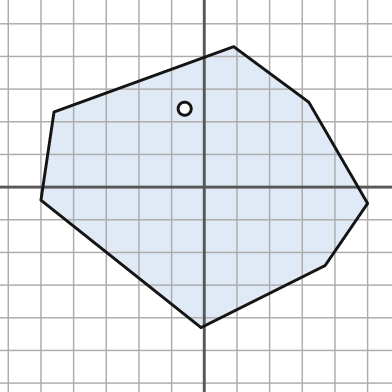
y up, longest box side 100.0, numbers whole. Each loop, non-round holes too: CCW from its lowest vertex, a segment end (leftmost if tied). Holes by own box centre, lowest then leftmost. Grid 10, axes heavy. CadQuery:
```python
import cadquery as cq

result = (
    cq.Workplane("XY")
    .moveTo(-1.0, -43.0)
    .lineTo(37.0, -24.0)
    .lineTo(50.0, -5.0)
    .lineTo(32.0, 26.0)
    .lineTo(9.0, 43.0)
    .lineTo(-46.0, 23.0)
    .lineTo(-50.0, -4.0)
    .close()
    .moveTo(-6.0, 24.0)
    .circle(2.0)
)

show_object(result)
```